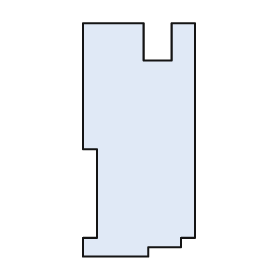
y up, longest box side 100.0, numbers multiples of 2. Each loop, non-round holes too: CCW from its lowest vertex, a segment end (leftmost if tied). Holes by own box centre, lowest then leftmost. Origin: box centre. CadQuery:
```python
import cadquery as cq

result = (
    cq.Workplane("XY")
    .moveTo(-24.0, -50.0)
    .lineTo(4.0, -50.0)
    .lineTo(4.0, -46.0)
    .lineTo(18.0, -46.0)
    .lineTo(18.0, -42.0)
    .lineTo(24.0, -42.0)
    .lineTo(24.0, 50.0)
    .lineTo(14.0, 50.0)
    .lineTo(14.0, 34.0)
    .lineTo(2.0, 34.0)
    .lineTo(2.0, 50.0)
    .lineTo(-24.0, 50.0)
    .lineTo(-24.0, -4.0)
    .lineTo(-18.0, -4.0)
    .lineTo(-18.0, -42.0)
    .lineTo(-24.0, -42.0)
    .close()
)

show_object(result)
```